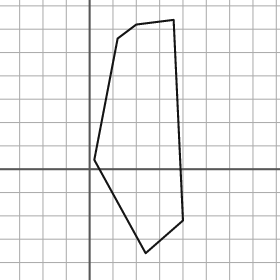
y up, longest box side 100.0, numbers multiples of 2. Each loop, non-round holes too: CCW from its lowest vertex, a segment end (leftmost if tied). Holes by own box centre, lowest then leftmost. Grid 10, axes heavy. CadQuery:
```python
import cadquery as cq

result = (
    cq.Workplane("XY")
    .moveTo(24.0, -36.0)
    .lineTo(40.0, -22.0)
    .lineTo(36.0, 64.0)
    .lineTo(20.0, 62.0)
    .lineTo(12.0, 56.0)
    .lineTo(2.0, 4.0)
    .close()
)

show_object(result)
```